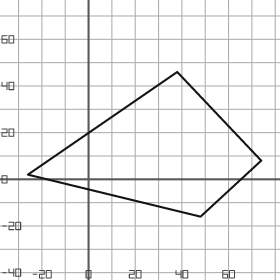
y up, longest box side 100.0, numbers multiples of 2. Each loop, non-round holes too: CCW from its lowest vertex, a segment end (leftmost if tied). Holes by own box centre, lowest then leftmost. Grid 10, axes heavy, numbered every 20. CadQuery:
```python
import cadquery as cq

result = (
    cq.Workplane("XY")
    .moveTo(48.0, -16.0)
    .lineTo(74.0, 8.0)
    .lineTo(38.0, 46.0)
    .lineTo(-26.0, 2.0)
    .close()
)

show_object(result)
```